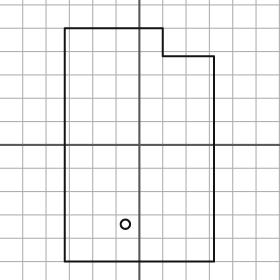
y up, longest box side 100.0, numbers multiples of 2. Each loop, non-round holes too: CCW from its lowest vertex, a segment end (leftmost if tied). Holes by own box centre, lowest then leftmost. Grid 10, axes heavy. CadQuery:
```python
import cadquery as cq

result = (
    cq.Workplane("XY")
    .moveTo(-32.0, -50.0)
    .lineTo(32.0, -50.0)
    .lineTo(32.0, 38.0)
    .lineTo(10.0, 38.0)
    .lineTo(10.0, 50.0)
    .lineTo(-32.0, 50.0)
    .close()
    .moveTo(-6.0, -34.0)
    .circle(2.0)
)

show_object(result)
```